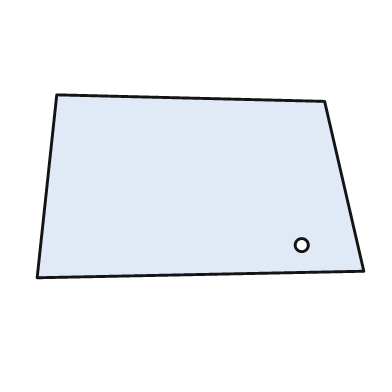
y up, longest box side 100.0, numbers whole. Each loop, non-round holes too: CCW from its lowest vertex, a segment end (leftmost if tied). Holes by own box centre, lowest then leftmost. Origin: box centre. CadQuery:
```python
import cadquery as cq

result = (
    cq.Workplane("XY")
    .moveTo(-50.0, -28.0)
    .lineTo(50.0, -26.0)
    .lineTo(38.0, 26.0)
    .lineTo(-44.0, 28.0)
    .close()
    .moveTo(31.0, -18.0)
    .circle(2.0)
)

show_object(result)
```